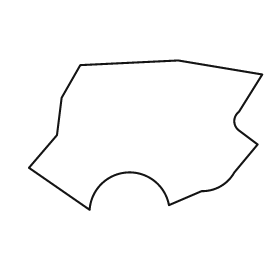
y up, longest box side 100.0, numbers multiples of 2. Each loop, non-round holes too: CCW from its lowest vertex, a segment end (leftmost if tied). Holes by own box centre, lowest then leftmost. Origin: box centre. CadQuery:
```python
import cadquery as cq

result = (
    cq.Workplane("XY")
    .moveTo(-24.0, -32.0)
    .threePointArc((-8.0, -16.0), (10.0, -30.0))
    .lineTo(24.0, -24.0)
    .threePointArc((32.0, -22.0), (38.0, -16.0))
    .lineTo(48.0, -4.0)
    .lineTo(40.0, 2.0)
    .threePointArc((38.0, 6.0), (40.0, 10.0))
    .lineTo(50.0, 26.0)
    .lineTo(14.0, 32.0)
    .lineTo(-28.0, 30.0)
    .lineTo(-36.0, 16.0)
    .lineTo(-38.0, 0.0)
    .lineTo(-50.0, -14.0)
    .close()
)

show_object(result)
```